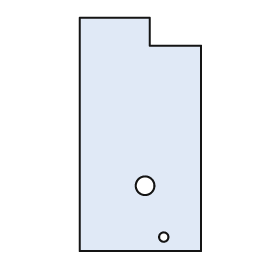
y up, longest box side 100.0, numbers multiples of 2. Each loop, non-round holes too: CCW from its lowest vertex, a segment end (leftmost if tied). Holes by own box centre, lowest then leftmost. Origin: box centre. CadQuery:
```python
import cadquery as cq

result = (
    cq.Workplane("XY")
    .moveTo(-26.0, -50.0)
    .lineTo(26.0, -50.0)
    .lineTo(26.0, 38.0)
    .lineTo(4.0, 38.0)
    .lineTo(4.0, 50.0)
    .lineTo(-26.0, 50.0)
    .close()
    .moveTo(10.0, -44.0)
    .circle(2.0)
    .moveTo(2.0, -22.0)
    .circle(4.0)
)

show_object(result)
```